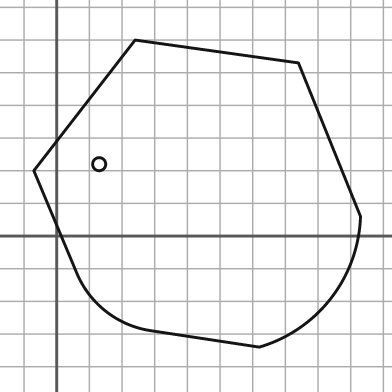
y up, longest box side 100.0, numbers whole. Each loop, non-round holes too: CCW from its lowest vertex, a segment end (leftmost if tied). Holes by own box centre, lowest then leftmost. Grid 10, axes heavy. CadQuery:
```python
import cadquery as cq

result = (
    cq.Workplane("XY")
    .moveTo(62.0, -34.0)
    .threePointArc((84.0, -19.0), (93.0, 6.0))
    .lineTo(74.0, 53.0)
    .lineTo(24.0, 60.0)
    .lineTo(-7.0, 20.0)
    .lineTo(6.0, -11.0)
    .threePointArc((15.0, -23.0), (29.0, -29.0))
    .close()
    .moveTo(13.0, 22.0)
    .circle(2.0)
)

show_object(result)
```